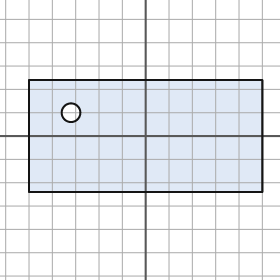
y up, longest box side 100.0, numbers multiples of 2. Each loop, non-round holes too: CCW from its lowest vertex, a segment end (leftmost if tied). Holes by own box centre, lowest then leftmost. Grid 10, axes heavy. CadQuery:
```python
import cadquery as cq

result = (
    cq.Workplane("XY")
    .moveTo(-50.0, -24.0)
    .lineTo(50.0, -24.0)
    .lineTo(50.0, 24.0)
    .lineTo(-50.0, 24.0)
    .close()
    .moveTo(-32.0, 10.0)
    .circle(4.0)
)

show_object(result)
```